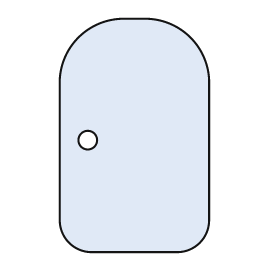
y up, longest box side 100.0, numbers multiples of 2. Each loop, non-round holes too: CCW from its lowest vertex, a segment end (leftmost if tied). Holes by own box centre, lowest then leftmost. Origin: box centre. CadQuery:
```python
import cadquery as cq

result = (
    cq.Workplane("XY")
    .moveTo(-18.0, -50.0)
    .lineTo(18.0, -50.0)
    .threePointArc((28.0, -46.0), (32.0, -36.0))
    .lineTo(32.0, 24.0)
    .threePointArc((24.0, 42.0), (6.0, 50.0))
    .lineTo(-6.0, 50.0)
    .threePointArc((-24.0, 42.0), (-32.0, 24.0))
    .lineTo(-32.0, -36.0)
    .threePointArc((-28.0, -46.0), (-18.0, -50.0))
    .close()
    .moveTo(-20.0, -2.0)
    .circle(4.0)
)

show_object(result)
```